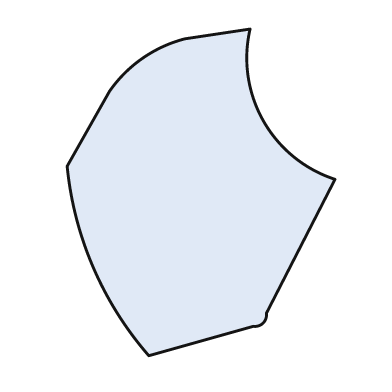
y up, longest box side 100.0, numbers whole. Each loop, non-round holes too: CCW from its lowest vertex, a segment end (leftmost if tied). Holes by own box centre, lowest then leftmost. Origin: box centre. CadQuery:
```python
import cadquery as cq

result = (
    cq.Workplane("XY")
    .moveTo(-16.0, -50.0)
    .lineTo(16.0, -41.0)
    .threePointArc((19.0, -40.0), (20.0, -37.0))
    .lineTo(41.0, 4.0)
    .threePointArc((19.0, 22.0), (15.0, 50.0))
    .lineTo(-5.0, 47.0)
    .threePointArc((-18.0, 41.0), (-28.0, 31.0))
    .lineTo(-41.0, 8.0)
    .threePointArc((-33.0, -23.0), (-16.0, -50.0))
    .close()
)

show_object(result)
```